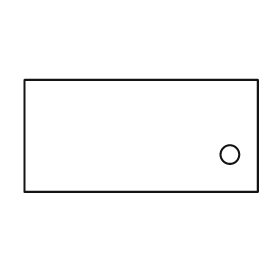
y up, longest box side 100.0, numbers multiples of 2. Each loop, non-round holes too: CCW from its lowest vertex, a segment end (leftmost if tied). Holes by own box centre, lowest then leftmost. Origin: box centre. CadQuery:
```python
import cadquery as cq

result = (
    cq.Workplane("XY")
    .moveTo(-50.0, -24.0)
    .lineTo(50.0, -24.0)
    .lineTo(50.0, 24.0)
    .lineTo(-50.0, 24.0)
    .close()
    .moveTo(38.0, -8.0)
    .circle(4.0)
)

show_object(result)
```